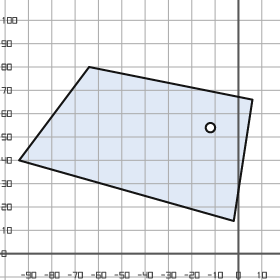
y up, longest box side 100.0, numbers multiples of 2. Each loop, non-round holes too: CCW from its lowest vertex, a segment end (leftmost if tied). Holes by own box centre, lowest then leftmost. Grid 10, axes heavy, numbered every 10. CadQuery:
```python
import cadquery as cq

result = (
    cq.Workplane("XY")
    .moveTo(-2.0, 14.0)
    .lineTo(6.0, 66.0)
    .lineTo(-64.0, 80.0)
    .lineTo(-94.0, 40.0)
    .close()
    .moveTo(-12.0, 54.0)
    .circle(2.0)
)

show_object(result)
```